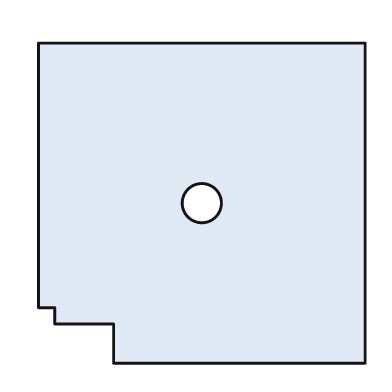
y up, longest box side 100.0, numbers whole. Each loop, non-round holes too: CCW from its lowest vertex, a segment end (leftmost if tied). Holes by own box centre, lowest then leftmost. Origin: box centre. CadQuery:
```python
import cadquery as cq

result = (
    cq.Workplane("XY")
    .moveTo(-27.0, -49.0)
    .lineTo(50.0, -49.0)
    .lineTo(50.0, 49.0)
    .lineTo(-50.0, 49.0)
    .lineTo(-50.0, -32.0)
    .lineTo(-45.0, -32.0)
    .lineTo(-45.0, -37.0)
    .lineTo(-27.0, -37.0)
    .close()
    .moveTo(0.0, 0.0)
    .circle(6.0)
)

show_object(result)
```